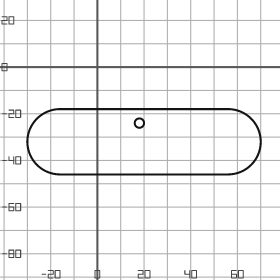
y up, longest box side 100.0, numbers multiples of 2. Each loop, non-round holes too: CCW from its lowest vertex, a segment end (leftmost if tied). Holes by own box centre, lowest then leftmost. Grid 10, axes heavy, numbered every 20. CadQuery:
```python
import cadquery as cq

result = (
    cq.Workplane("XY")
    .moveTo(-16.0, -46.0)
    .lineTo(56.0, -46.0)
    .threePointArc((70.0, -32.0), (56.0, -18.0))
    .lineTo(-16.0, -18.0)
    .threePointArc((-30.0, -32.0), (-16.0, -46.0))
    .close()
    .moveTo(18.0, -24.0)
    .circle(2.0)
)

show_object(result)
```